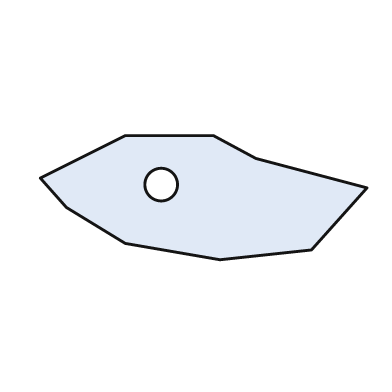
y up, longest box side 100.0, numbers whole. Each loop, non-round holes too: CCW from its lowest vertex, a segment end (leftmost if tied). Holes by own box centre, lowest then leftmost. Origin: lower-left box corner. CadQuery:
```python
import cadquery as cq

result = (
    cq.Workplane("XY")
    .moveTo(55.0, 0.0)
    .lineTo(83.0, 3.0)
    .lineTo(100.0, 22.0)
    .lineTo(66.0, 31.0)
    .lineTo(53.0, 38.0)
    .lineTo(26.0, 38.0)
    .lineTo(0.0, 25.0)
    .lineTo(8.0, 16.0)
    .lineTo(26.0, 5.0)
    .close()
    .moveTo(37.0, 23.0)
    .circle(5.0)
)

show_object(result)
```